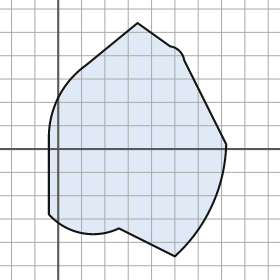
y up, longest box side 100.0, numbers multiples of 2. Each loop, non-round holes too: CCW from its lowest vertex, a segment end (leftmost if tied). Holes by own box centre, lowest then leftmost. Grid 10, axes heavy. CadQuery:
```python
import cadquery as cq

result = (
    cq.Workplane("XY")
    .moveTo(50.0, -46.0)
    .threePointArc((66.0, -24.0), (72.0, 2.0))
    .lineTo(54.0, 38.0)
    .threePointArc((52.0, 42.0), (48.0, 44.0))
    .lineTo(34.0, 54.0)
    .lineTo(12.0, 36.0)
    .threePointArc((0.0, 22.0), (-4.0, 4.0))
    .lineTo(-4.0, -28.0)
    .threePointArc((10.0, -36.0), (26.0, -34.0))
    .close()
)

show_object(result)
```